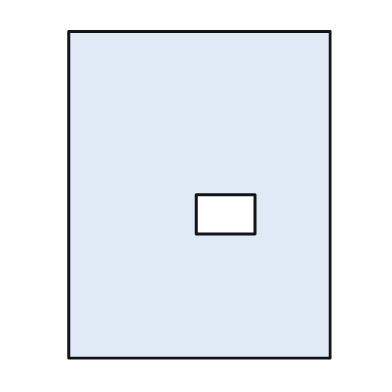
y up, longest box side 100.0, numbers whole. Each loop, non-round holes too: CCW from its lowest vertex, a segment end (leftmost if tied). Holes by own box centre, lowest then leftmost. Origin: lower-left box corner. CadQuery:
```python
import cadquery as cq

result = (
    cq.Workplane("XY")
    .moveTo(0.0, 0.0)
    .lineTo(80.0, 0.0)
    .lineTo(80.0, 100.0)
    .lineTo(0.0, 100.0)
    .close()
    .moveTo(39.0, 38.0)
    .lineTo(57.0, 38.0)
    .lineTo(57.0, 50.0)
    .lineTo(39.0, 50.0)
    .close()
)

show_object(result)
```